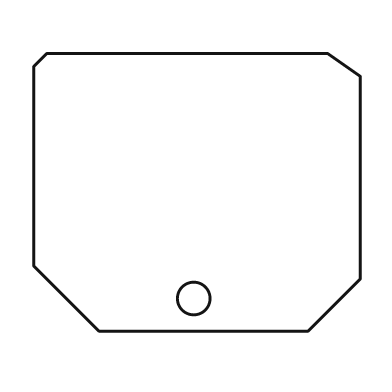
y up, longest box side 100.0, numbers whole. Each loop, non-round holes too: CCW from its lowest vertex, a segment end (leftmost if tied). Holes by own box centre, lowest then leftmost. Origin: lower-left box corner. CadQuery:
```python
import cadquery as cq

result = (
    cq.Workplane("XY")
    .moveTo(20.0, 0.0)
    .lineTo(84.0, 0.0)
    .lineTo(100.0, 16.0)
    .lineTo(100.0, 78.0)
    .lineTo(90.0, 85.0)
    .lineTo(4.0, 85.0)
    .lineTo(0.0, 81.0)
    .lineTo(0.0, 20.0)
    .close()
    .moveTo(49.0, 10.0)
    .circle(5.0)
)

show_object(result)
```